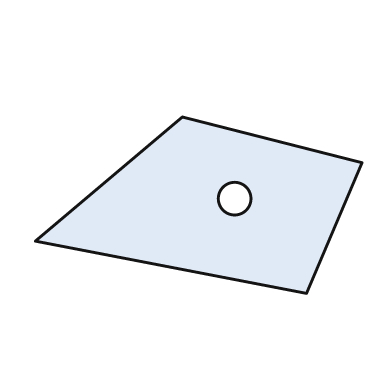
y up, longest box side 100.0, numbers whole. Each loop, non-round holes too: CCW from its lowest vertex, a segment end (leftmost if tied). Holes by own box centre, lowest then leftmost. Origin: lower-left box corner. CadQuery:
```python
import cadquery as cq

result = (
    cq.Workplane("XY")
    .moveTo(83.0, 0.0)
    .lineTo(100.0, 40.0)
    .lineTo(45.0, 54.0)
    .lineTo(0.0, 16.0)
    .close()
    .moveTo(61.0, 29.0)
    .circle(5.0)
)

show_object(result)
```